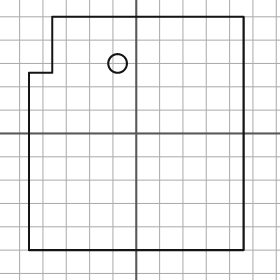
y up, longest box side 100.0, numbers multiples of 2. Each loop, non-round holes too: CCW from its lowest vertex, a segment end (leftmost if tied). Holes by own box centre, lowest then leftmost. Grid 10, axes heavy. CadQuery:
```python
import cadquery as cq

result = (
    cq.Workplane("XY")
    .moveTo(-46.0, -50.0)
    .lineTo(46.0, -50.0)
    .lineTo(46.0, 50.0)
    .lineTo(-36.0, 50.0)
    .lineTo(-36.0, 26.0)
    .lineTo(-46.0, 26.0)
    .close()
    .moveTo(-8.0, 30.0)
    .circle(4.0)
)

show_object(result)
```